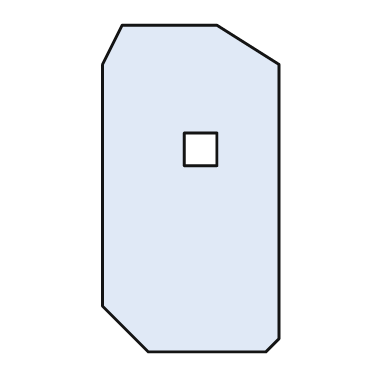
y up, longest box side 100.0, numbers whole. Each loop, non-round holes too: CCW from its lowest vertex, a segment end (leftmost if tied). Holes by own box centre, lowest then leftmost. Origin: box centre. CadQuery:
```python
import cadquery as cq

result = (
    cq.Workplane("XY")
    .moveTo(-13.0, -50.0)
    .lineTo(23.0, -50.0)
    .lineTo(27.0, -46.0)
    .lineTo(27.0, 38.0)
    .lineTo(8.0, 50.0)
    .lineTo(-21.0, 50.0)
    .lineTo(-27.0, 38.0)
    .lineTo(-27.0, -36.0)
    .close()
    .moveTo(-2.0, 7.0)
    .lineTo(8.0, 7.0)
    .lineTo(8.0, 17.0)
    .lineTo(-2.0, 17.0)
    .close()
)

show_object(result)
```